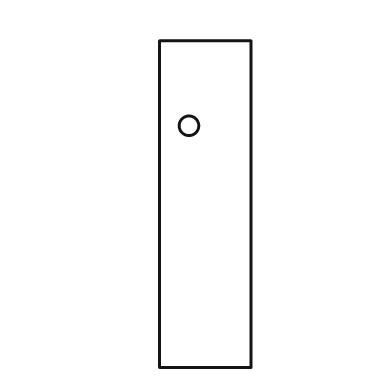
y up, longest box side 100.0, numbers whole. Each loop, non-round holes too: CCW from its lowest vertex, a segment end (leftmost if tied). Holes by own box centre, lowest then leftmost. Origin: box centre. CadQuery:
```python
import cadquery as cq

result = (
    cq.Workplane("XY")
    .moveTo(-14.0, -50.0)
    .lineTo(14.0, -50.0)
    .lineTo(14.0, 50.0)
    .lineTo(-14.0, 50.0)
    .close()
    .moveTo(-5.0, 24.0)
    .circle(3.0)
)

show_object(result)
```